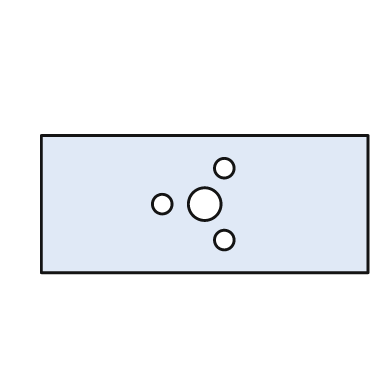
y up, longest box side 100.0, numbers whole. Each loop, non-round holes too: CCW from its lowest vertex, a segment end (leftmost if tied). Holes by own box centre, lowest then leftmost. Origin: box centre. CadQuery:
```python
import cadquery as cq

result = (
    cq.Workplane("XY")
    .moveTo(-50.0, -21.0)
    .lineTo(50.0, -21.0)
    .lineTo(50.0, 21.0)
    .lineTo(-50.0, 21.0)
    .close()
    .moveTo(6.0, -11.0)
    .circle(3.0)
    .moveTo(-13.0, 0.0)
    .circle(3.0)
    .moveTo(0.0, 0.0)
    .circle(5.0)
    .moveTo(6.0, 11.0)
    .circle(3.0)
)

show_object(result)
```